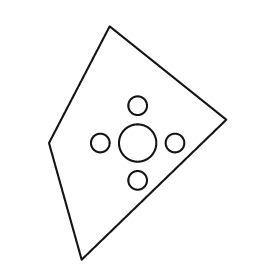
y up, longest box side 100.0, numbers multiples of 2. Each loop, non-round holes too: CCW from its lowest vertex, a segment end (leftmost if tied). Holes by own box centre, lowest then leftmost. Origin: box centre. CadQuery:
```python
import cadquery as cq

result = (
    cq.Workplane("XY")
    .moveTo(-24.0, -50.0)
    .lineTo(38.0, 10.0)
    .lineTo(-12.0, 50.0)
    .lineTo(-38.0, 0.0)
    .close()
    .moveTo(0.0, -16.0)
    .circle(4.0)
    .moveTo(-16.0, 0.0)
    .circle(4.0)
    .moveTo(0.0, 0.0)
    .circle(8.0)
    .moveTo(16.0, 0.0)
    .circle(4.0)
    .moveTo(0.0, 16.0)
    .circle(4.0)
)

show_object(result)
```